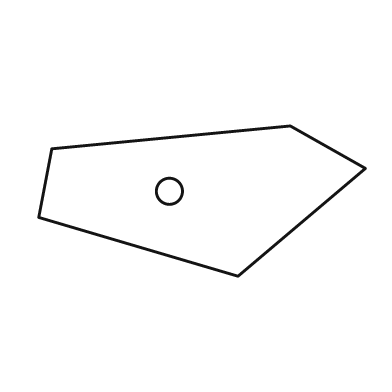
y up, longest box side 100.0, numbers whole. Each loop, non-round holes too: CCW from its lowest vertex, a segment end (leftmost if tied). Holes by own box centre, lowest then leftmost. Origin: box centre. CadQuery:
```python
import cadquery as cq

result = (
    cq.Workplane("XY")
    .moveTo(11.0, -23.0)
    .lineTo(50.0, 10.0)
    .lineTo(27.0, 23.0)
    .lineTo(-46.0, 16.0)
    .lineTo(-50.0, -5.0)
    .close()
    .moveTo(-10.0, 3.0)
    .circle(4.0)
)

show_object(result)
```